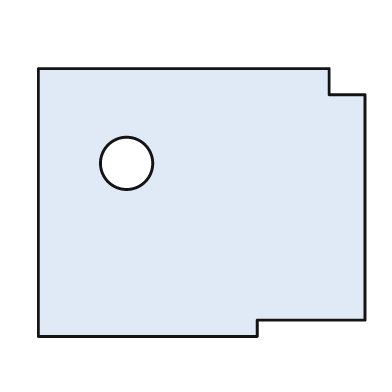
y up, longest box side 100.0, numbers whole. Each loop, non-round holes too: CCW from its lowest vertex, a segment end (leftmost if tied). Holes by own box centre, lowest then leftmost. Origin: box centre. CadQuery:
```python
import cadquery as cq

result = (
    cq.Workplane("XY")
    .moveTo(-50.0, -41.0)
    .lineTo(17.0, -41.0)
    .lineTo(17.0, -36.0)
    .lineTo(50.0, -36.0)
    .lineTo(50.0, 33.0)
    .lineTo(39.0, 33.0)
    .lineTo(39.0, 41.0)
    .lineTo(-50.0, 41.0)
    .close()
    .moveTo(-23.0, 12.0)
    .circle(8.0)
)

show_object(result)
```